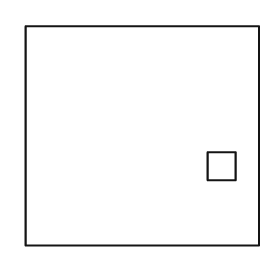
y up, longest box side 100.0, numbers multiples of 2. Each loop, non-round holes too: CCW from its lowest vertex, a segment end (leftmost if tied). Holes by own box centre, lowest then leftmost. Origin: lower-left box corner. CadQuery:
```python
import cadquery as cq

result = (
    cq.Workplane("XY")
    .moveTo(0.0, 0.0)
    .lineTo(100.0, 0.0)
    .lineTo(100.0, 94.0)
    .lineTo(0.0, 94.0)
    .close()
    .moveTo(78.0, 28.0)
    .lineTo(90.0, 28.0)
    .lineTo(90.0, 40.0)
    .lineTo(78.0, 40.0)
    .close()
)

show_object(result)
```